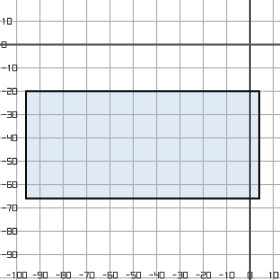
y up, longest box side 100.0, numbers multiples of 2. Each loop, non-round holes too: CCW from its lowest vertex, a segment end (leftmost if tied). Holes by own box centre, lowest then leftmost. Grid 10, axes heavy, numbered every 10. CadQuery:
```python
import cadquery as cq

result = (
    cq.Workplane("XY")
    .moveTo(-96.0, -66.0)
    .lineTo(4.0, -66.0)
    .lineTo(4.0, -20.0)
    .lineTo(-96.0, -20.0)
    .close()
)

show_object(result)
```